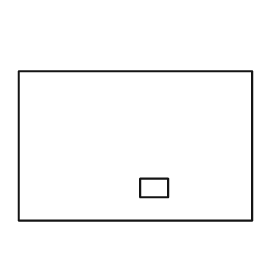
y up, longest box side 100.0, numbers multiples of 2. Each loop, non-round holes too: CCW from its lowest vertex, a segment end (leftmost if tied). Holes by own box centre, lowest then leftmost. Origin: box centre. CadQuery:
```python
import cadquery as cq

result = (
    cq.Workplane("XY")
    .moveTo(-50.0, -32.0)
    .lineTo(50.0, -32.0)
    .lineTo(50.0, 32.0)
    .lineTo(-50.0, 32.0)
    .close()
    .moveTo(2.0, -22.0)
    .lineTo(14.0, -22.0)
    .lineTo(14.0, -14.0)
    .lineTo(2.0, -14.0)
    .close()
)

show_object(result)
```